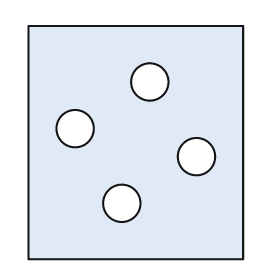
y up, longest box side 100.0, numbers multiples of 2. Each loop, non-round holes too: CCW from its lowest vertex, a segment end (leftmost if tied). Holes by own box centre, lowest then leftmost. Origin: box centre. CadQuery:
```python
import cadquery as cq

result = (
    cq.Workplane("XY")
    .moveTo(-46.0, -50.0)
    .lineTo(46.0, -50.0)
    .lineTo(46.0, 50.0)
    .lineTo(-46.0, 50.0)
    .close()
    .moveTo(-6.0, -26.0)
    .circle(8.0)
    .moveTo(26.0, -6.0)
    .circle(8.0)
    .moveTo(-26.0, 6.0)
    .circle(8.0)
    .moveTo(6.0, 26.0)
    .circle(8.0)
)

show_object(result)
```